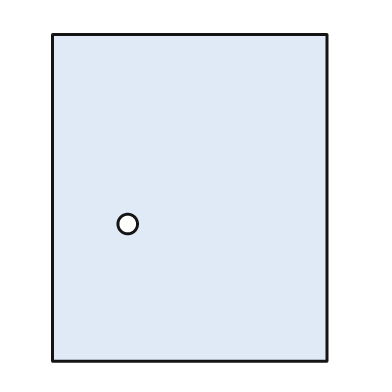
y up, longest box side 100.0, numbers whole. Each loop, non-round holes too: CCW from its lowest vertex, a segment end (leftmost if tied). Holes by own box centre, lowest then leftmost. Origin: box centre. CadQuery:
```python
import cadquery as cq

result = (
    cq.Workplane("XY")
    .moveTo(-42.0, -50.0)
    .lineTo(42.0, -50.0)
    .lineTo(42.0, 50.0)
    .lineTo(-42.0, 50.0)
    .close()
    .moveTo(-19.0, -8.0)
    .circle(3.0)
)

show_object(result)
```